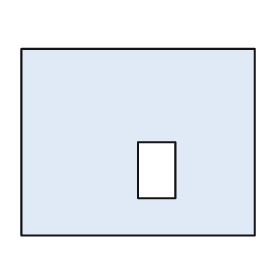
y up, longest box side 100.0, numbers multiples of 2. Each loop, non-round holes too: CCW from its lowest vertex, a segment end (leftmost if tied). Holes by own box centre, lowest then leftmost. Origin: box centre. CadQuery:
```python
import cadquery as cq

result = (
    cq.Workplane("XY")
    .moveTo(-50.0, -40.0)
    .lineTo(50.0, -40.0)
    .lineTo(50.0, 40.0)
    .lineTo(-50.0, 40.0)
    .close()
    .moveTo(0.0, -24.0)
    .lineTo(16.0, -24.0)
    .lineTo(16.0, 0.0)
    .lineTo(0.0, 0.0)
    .close()
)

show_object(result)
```